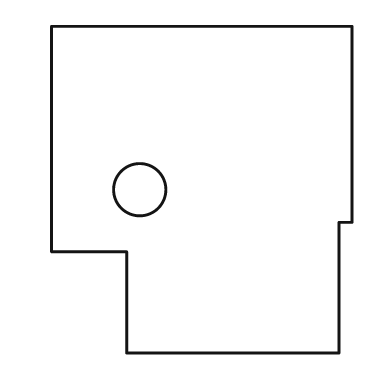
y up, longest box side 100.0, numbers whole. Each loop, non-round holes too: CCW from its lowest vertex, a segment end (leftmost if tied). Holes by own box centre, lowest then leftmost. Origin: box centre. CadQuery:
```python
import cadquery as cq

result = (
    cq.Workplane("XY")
    .moveTo(-23.0, -50.0)
    .lineTo(42.0, -50.0)
    .lineTo(42.0, -10.0)
    .lineTo(46.0, -10.0)
    .lineTo(46.0, 50.0)
    .lineTo(-46.0, 50.0)
    .lineTo(-46.0, -19.0)
    .lineTo(-23.0, -19.0)
    .close()
    .moveTo(-19.0, 0.0)
    .circle(8.0)
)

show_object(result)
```